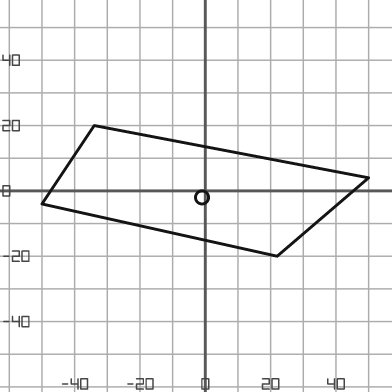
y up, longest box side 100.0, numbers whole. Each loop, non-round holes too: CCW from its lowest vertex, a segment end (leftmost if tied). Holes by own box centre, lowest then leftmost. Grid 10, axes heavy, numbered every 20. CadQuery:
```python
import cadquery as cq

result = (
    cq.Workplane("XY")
    .moveTo(22.0, -20.0)
    .lineTo(50.0, 4.0)
    .lineTo(-34.0, 20.0)
    .lineTo(-50.0, -4.0)
    .close()
    .moveTo(-1.0, -2.0)
    .circle(2.0)
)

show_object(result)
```